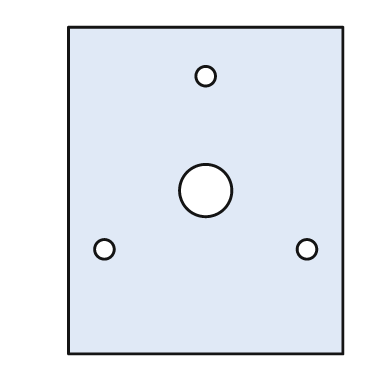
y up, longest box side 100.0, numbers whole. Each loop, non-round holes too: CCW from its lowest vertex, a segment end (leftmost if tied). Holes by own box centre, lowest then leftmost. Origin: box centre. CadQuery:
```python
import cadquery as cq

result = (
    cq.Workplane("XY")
    .moveTo(-42.0, -50.0)
    .lineTo(42.0, -50.0)
    .lineTo(42.0, 50.0)
    .lineTo(-42.0, 50.0)
    .close()
    .moveTo(-31.0, -18.0)
    .circle(3.0)
    .moveTo(31.0, -18.0)
    .circle(3.0)
    .moveTo(0.0, 0.0)
    .circle(8.0)
    .moveTo(0.0, 35.0)
    .circle(3.0)
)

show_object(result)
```